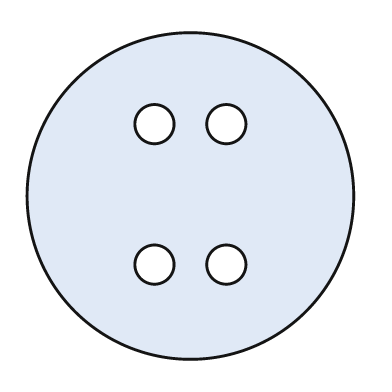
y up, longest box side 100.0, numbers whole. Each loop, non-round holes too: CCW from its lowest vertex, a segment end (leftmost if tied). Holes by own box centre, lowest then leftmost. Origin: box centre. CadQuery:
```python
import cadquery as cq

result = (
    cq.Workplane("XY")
    .moveTo(0.0, 0.0)
    .circle(50.0)
    .moveTo(-11.0, -21.0)
    .circle(6.0)
    .moveTo(11.0, -21.0)
    .circle(6.0)
    .moveTo(-11.0, 22.0)
    .circle(6.0)
    .moveTo(11.0, 22.0)
    .circle(6.0)
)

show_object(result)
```